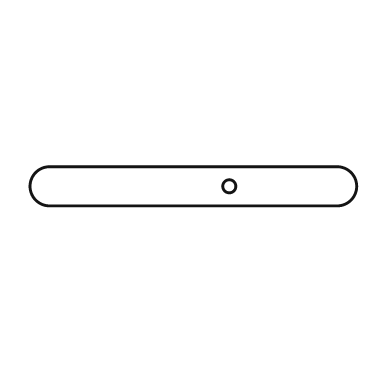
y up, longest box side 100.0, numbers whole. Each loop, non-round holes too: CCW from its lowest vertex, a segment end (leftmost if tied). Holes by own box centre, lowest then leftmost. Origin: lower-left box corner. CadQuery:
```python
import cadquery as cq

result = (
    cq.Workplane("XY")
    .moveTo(6.0, 0.0)
    .lineTo(94.0, 0.0)
    .threePointArc((100.0, 6.0), (94.0, 12.0))
    .lineTo(6.0, 12.0)
    .threePointArc((0.0, 6.0), (6.0, 0.0))
    .close()
    .moveTo(61.0, 6.0)
    .circle(2.0)
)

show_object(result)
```